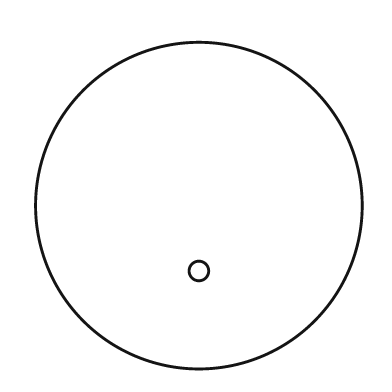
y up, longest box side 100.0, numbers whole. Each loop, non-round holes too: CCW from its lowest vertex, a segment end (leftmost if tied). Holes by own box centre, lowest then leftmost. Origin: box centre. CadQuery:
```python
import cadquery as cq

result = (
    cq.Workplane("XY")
    .moveTo(0.0, 0.0)
    .circle(50.0)
    .moveTo(0.0, -20.0)
    .circle(3.0)
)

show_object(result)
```